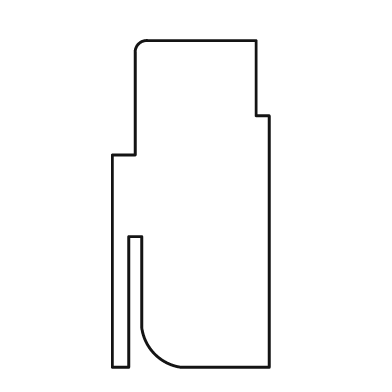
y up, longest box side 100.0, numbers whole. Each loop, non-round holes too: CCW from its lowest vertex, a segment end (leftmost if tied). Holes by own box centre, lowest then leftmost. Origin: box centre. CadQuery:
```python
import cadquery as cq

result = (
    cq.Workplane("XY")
    .moveTo(-24.0, -50.0)
    .lineTo(-19.0, -50.0)
    .lineTo(-19.0, -10.0)
    .lineTo(-15.0, -10.0)
    .lineTo(-15.0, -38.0)
    .threePointArc((-11.0, -46.0), (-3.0, -50.0))
    .lineTo(24.0, -50.0)
    .lineTo(24.0, 27.0)
    .lineTo(20.0, 27.0)
    .lineTo(20.0, 50.0)
    .lineTo(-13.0, 50.0)
    .threePointArc((-16.0, 49.0), (-17.0, 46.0))
    .lineTo(-17.0, 15.0)
    .lineTo(-24.0, 15.0)
    .close()
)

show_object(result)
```